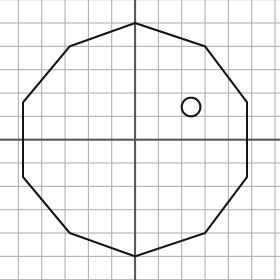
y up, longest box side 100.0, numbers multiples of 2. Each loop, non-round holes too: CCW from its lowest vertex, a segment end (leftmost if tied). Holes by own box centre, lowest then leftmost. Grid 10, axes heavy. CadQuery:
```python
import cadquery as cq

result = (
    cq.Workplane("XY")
    .moveTo(0.0, -50.0)
    .lineTo(30.0, -40.0)
    .lineTo(48.0, -16.0)
    .lineTo(48.0, 16.0)
    .lineTo(30.0, 40.0)
    .lineTo(0.0, 50.0)
    .lineTo(-28.0, 40.0)
    .lineTo(-48.0, 16.0)
    .lineTo(-48.0, -16.0)
    .lineTo(-28.0, -40.0)
    .close()
    .moveTo(24.0, 14.0)
    .circle(4.0)
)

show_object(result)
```